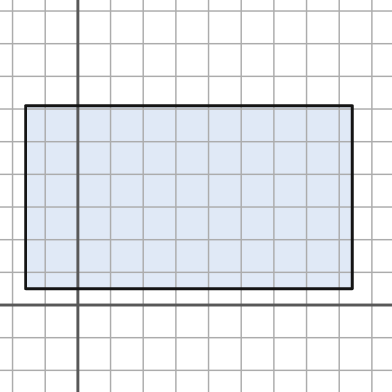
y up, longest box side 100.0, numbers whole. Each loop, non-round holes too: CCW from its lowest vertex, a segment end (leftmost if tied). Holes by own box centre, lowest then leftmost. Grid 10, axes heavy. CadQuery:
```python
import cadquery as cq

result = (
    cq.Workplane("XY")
    .moveTo(-16.0, 5.0)
    .lineTo(84.0, 5.0)
    .lineTo(84.0, 61.0)
    .lineTo(-16.0, 61.0)
    .close()
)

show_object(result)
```